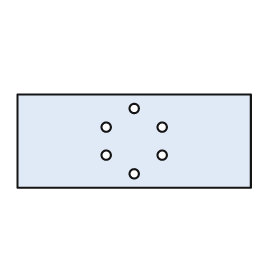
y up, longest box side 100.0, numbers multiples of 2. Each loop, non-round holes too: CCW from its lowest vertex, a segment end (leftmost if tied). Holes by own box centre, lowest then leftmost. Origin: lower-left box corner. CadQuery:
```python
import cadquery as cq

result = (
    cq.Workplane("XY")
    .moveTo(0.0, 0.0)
    .lineTo(100.0, 0.0)
    .lineTo(100.0, 40.0)
    .lineTo(0.0, 40.0)
    .close()
    .moveTo(50.0, 6.0)
    .circle(2.0)
    .moveTo(38.0, 14.0)
    .circle(2.0)
    .moveTo(62.0, 14.0)
    .circle(2.0)
    .moveTo(38.0, 26.0)
    .circle(2.0)
    .moveTo(62.0, 26.0)
    .circle(2.0)
    .moveTo(50.0, 34.0)
    .circle(2.0)
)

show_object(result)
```